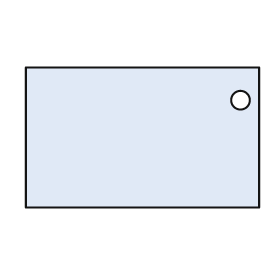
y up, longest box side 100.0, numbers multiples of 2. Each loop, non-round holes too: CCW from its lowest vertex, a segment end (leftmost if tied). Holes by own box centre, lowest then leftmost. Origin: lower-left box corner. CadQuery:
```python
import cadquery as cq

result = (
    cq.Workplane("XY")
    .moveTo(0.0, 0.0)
    .lineTo(100.0, 0.0)
    .lineTo(100.0, 60.0)
    .lineTo(0.0, 60.0)
    .close()
    .moveTo(92.0, 46.0)
    .circle(4.0)
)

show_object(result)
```